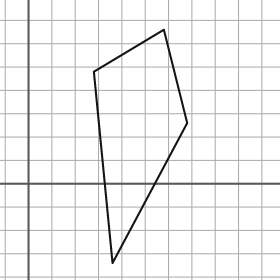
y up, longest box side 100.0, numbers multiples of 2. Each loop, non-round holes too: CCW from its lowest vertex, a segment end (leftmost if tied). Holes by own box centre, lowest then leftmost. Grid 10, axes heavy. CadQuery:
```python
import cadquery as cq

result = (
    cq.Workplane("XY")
    .moveTo(36.0, -34.0)
    .lineTo(68.0, 26.0)
    .lineTo(58.0, 66.0)
    .lineTo(28.0, 48.0)
    .close()
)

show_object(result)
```